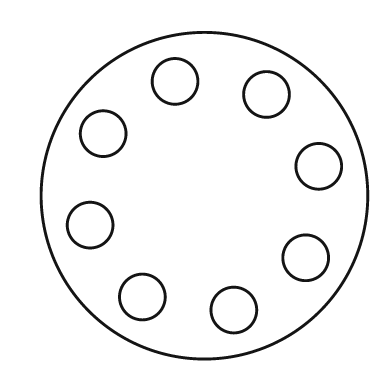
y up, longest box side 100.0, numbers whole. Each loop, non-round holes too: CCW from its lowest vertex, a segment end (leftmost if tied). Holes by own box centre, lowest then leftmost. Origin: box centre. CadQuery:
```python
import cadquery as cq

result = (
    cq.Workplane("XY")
    .moveTo(0.0, 0.0)
    .circle(50.0)
    .moveTo(9.0, -35.0)
    .circle(7.0)
    .moveTo(-19.0, -31.0)
    .circle(7.0)
    .moveTo(31.0, -19.0)
    .circle(7.0)
    .moveTo(-35.0, -9.0)
    .circle(7.0)
    .moveTo(35.0, 9.0)
    .circle(7.0)
    .moveTo(-31.0, 19.0)
    .circle(7.0)
    .moveTo(19.0, 31.0)
    .circle(7.0)
    .moveTo(-9.0, 35.0)
    .circle(7.0)
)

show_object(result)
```